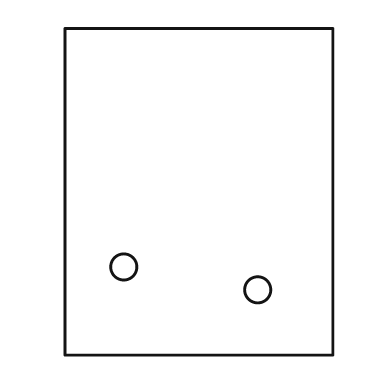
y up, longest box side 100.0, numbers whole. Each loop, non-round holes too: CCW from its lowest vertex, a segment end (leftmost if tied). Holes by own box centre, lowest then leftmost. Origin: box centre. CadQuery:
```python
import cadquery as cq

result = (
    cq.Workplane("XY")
    .moveTo(-41.0, -50.0)
    .lineTo(41.0, -50.0)
    .lineTo(41.0, 50.0)
    .lineTo(-41.0, 50.0)
    .close()
    .moveTo(18.0, -30.0)
    .circle(4.0)
    .moveTo(-23.0, -23.0)
    .circle(4.0)
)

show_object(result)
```